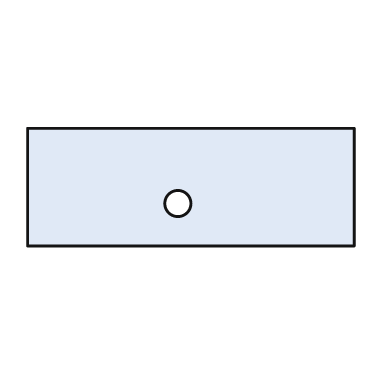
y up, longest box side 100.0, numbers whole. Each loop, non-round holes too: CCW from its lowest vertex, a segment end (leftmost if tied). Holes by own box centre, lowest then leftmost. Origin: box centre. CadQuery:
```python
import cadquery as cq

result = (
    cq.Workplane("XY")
    .moveTo(-50.0, -18.0)
    .lineTo(50.0, -18.0)
    .lineTo(50.0, 18.0)
    .lineTo(-50.0, 18.0)
    .close()
    .moveTo(-4.0, -5.0)
    .circle(4.0)
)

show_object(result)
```